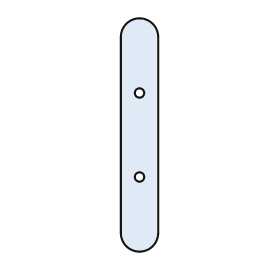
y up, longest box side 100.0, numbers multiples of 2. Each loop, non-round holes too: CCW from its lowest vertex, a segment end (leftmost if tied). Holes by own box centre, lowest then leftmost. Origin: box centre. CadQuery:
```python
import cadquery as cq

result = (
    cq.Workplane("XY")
    .moveTo(-8.0, -42.0)
    .threePointArc((0.0, -50.0), (8.0, -42.0))
    .lineTo(8.0, 42.0)
    .threePointArc((0.0, 50.0), (-8.0, 42.0))
    .close()
    .moveTo(0.0, -18.0)
    .circle(2.0)
    .moveTo(0.0, 18.0)
    .circle(2.0)
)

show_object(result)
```